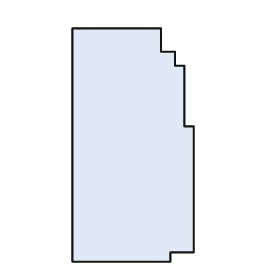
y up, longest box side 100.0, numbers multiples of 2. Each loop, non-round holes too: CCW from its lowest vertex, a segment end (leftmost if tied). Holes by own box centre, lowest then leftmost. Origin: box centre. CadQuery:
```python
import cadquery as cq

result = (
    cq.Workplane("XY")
    .moveTo(-26.0, -50.0)
    .lineTo(16.0, -50.0)
    .lineTo(16.0, -46.0)
    .lineTo(26.0, -46.0)
    .lineTo(26.0, 8.0)
    .lineTo(22.0, 8.0)
    .lineTo(22.0, 34.0)
    .lineTo(18.0, 34.0)
    .lineTo(18.0, 40.0)
    .lineTo(12.0, 40.0)
    .lineTo(12.0, 50.0)
    .lineTo(-26.0, 50.0)
    .close()
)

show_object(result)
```